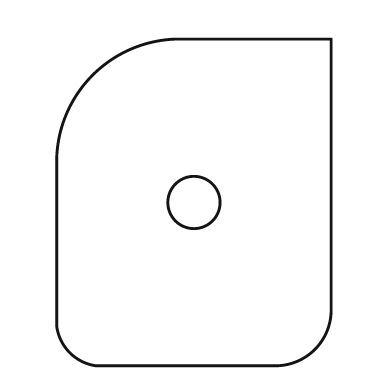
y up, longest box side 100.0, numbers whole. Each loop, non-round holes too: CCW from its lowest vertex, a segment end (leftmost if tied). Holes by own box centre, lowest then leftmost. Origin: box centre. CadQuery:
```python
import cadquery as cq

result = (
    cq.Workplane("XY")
    .moveTo(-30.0, -50.0)
    .lineTo(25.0, -50.0)
    .threePointArc((37.0, -45.0), (42.0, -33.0))
    .lineTo(42.0, 50.0)
    .lineTo(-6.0, 50.0)
    .threePointArc((-31.0, 39.0), (-42.0, 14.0))
    .lineTo(-42.0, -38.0)
    .threePointArc((-38.0, -46.0), (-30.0, -50.0))
    .close()
    .moveTo(0.0, 0.0)
    .circle(8.0)
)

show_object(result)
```